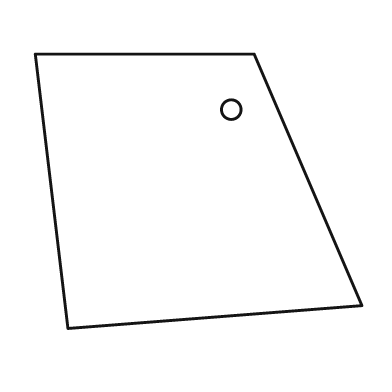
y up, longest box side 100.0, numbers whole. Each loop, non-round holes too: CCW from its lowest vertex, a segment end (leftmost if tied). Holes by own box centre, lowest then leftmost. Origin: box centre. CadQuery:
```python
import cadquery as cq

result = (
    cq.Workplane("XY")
    .moveTo(-40.0, -42.0)
    .lineTo(50.0, -35.0)
    .lineTo(17.0, 42.0)
    .lineTo(-50.0, 42.0)
    .close()
    .moveTo(10.0, 25.0)
    .circle(3.0)
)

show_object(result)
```